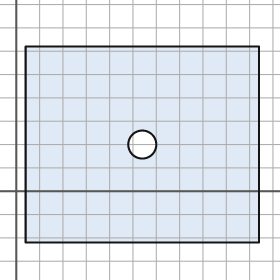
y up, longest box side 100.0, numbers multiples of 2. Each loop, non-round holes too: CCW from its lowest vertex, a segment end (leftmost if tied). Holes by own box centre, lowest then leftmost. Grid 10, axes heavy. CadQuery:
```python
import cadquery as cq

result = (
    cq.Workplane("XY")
    .moveTo(4.0, -22.0)
    .lineTo(104.0, -22.0)
    .lineTo(104.0, 62.0)
    .lineTo(4.0, 62.0)
    .close()
    .moveTo(54.0, 20.0)
    .circle(6.0)
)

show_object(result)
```